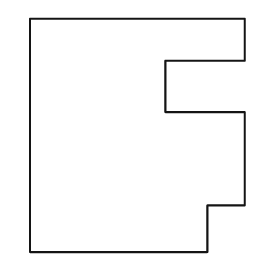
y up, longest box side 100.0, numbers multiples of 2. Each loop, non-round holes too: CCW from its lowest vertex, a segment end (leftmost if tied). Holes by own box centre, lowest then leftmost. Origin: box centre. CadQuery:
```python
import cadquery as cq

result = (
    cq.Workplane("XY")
    .moveTo(-46.0, -50.0)
    .lineTo(30.0, -50.0)
    .lineTo(30.0, -30.0)
    .lineTo(46.0, -30.0)
    .lineTo(46.0, 10.0)
    .lineTo(12.0, 10.0)
    .lineTo(12.0, 32.0)
    .lineTo(46.0, 32.0)
    .lineTo(46.0, 50.0)
    .lineTo(-46.0, 50.0)
    .close()
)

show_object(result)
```